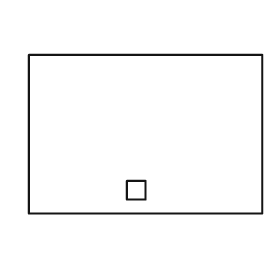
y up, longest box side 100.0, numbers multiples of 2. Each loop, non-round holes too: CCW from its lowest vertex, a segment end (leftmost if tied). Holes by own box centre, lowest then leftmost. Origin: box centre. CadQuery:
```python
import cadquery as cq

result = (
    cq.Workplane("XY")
    .moveTo(-50.0, -34.0)
    .lineTo(50.0, -34.0)
    .lineTo(50.0, 34.0)
    .lineTo(-50.0, 34.0)
    .close()
    .moveTo(-8.0, -28.0)
    .lineTo(0.0, -28.0)
    .lineTo(0.0, -20.0)
    .lineTo(-8.0, -20.0)
    .close()
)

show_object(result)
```